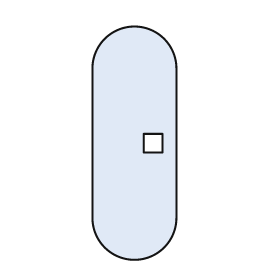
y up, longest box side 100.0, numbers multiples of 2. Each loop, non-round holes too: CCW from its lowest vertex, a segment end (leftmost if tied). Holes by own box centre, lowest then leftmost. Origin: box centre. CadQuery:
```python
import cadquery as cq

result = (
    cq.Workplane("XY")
    .moveTo(-18.0, -32.0)
    .threePointArc((0.0, -50.0), (18.0, -32.0))
    .lineTo(18.0, 32.0)
    .threePointArc((0.0, 50.0), (-18.0, 32.0))
    .close()
    .moveTo(4.0, -4.0)
    .lineTo(12.0, -4.0)
    .lineTo(12.0, 4.0)
    .lineTo(4.0, 4.0)
    .close()
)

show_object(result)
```